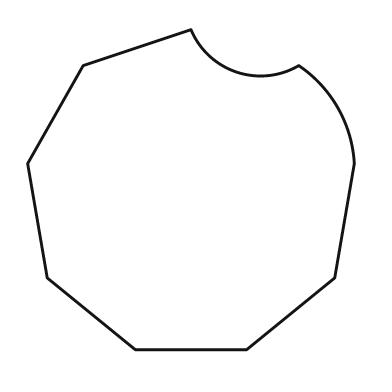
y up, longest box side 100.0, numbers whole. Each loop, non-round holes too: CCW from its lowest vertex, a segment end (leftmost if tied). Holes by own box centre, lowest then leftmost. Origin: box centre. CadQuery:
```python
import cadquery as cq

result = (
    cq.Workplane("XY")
    .moveTo(-17.0, -49.0)
    .lineTo(17.0, -49.0)
    .lineTo(44.0, -27.0)
    .lineTo(50.0, 8.0)
    .threePointArc((45.0, 25.0), (33.0, 38.0))
    .threePointArc((14.0, 36.0), (0.0, 49.0))
    .lineTo(-33.0, 38.0)
    .lineTo(-50.0, 8.0)
    .lineTo(-44.0, -27.0)
    .close()
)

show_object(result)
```